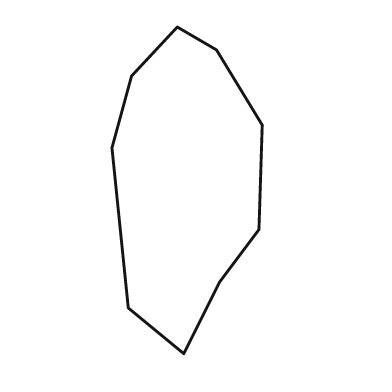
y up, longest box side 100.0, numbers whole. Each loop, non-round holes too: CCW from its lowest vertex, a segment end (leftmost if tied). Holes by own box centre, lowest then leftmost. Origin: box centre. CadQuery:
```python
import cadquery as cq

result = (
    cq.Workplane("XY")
    .moveTo(-1.0, -50.0)
    .lineTo(10.0, -28.0)
    .lineTo(22.0, -12.0)
    .lineTo(23.0, 20.0)
    .lineTo(9.0, 43.0)
    .lineTo(-3.0, 50.0)
    .lineTo(-17.0, 35.0)
    .lineTo(-23.0, 13.0)
    .lineTo(-18.0, -36.0)
    .close()
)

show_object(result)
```